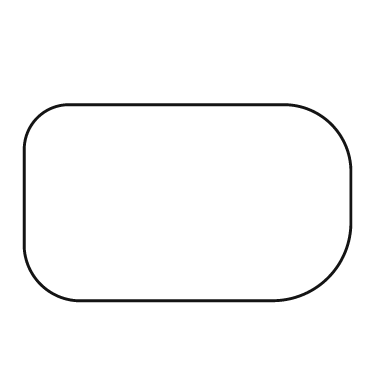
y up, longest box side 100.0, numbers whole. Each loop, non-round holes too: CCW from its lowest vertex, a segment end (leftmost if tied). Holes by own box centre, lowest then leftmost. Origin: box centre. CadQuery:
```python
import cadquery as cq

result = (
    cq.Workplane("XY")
    .moveTo(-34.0, -30.0)
    .lineTo(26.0, -30.0)
    .threePointArc((43.0, -23.0), (50.0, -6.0))
    .lineTo(50.0, 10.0)
    .threePointArc((44.0, 24.0), (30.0, 30.0))
    .lineTo(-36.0, 30.0)
    .threePointArc((-46.0, 26.0), (-50.0, 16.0))
    .lineTo(-50.0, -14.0)
    .threePointArc((-45.0, -25.0), (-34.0, -30.0))
    .close()
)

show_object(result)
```